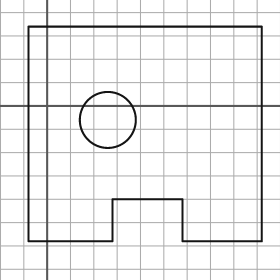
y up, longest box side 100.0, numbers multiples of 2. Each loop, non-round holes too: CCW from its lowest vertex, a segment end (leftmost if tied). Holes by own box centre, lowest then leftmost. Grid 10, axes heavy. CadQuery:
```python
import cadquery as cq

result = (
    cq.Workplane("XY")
    .moveTo(-8.0, -58.0)
    .lineTo(28.0, -58.0)
    .lineTo(28.0, -40.0)
    .lineTo(58.0, -40.0)
    .lineTo(58.0, -58.0)
    .lineTo(92.0, -58.0)
    .lineTo(92.0, 34.0)
    .lineTo(-8.0, 34.0)
    .close()
    .moveTo(26.0, -6.0)
    .circle(12.0)
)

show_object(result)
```